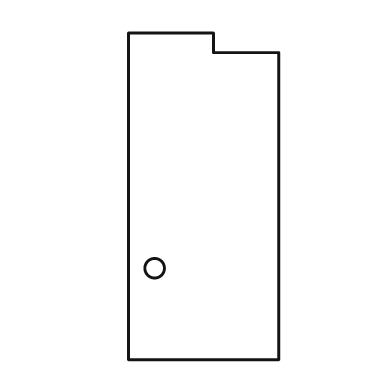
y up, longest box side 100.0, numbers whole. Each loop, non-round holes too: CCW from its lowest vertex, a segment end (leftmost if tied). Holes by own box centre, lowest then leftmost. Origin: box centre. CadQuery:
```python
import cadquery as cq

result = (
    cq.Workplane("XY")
    .moveTo(-23.0, -50.0)
    .lineTo(23.0, -50.0)
    .lineTo(23.0, 44.0)
    .lineTo(3.0, 44.0)
    .lineTo(3.0, 50.0)
    .lineTo(-23.0, 50.0)
    .close()
    .moveTo(-15.0, -22.0)
    .circle(3.0)
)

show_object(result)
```